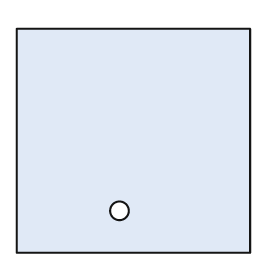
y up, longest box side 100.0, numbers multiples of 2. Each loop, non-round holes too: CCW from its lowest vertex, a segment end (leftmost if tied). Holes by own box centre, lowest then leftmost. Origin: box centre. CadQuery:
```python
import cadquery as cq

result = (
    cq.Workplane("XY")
    .moveTo(-50.0, -48.0)
    .lineTo(50.0, -48.0)
    .lineTo(50.0, 48.0)
    .lineTo(-50.0, 48.0)
    .close()
    .moveTo(-6.0, -30.0)
    .circle(4.0)
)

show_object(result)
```